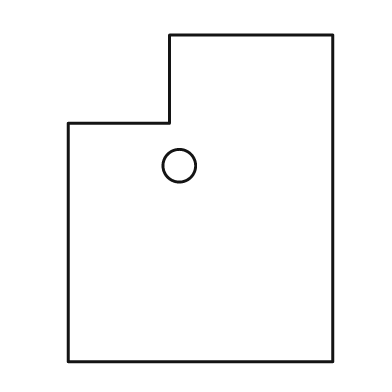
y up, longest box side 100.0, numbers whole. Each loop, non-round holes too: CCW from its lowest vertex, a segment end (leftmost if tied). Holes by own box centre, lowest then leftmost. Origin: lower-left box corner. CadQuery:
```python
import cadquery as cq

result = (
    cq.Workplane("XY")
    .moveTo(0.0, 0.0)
    .lineTo(81.0, 0.0)
    .lineTo(81.0, 100.0)
    .lineTo(31.0, 100.0)
    .lineTo(31.0, 73.0)
    .lineTo(0.0, 73.0)
    .close()
    .moveTo(34.0, 60.0)
    .circle(5.0)
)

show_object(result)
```